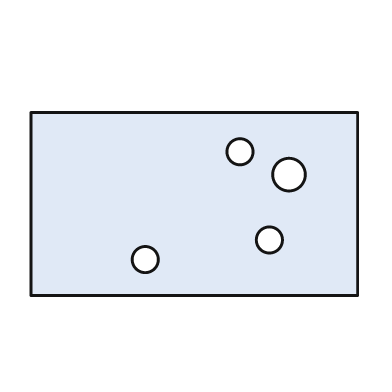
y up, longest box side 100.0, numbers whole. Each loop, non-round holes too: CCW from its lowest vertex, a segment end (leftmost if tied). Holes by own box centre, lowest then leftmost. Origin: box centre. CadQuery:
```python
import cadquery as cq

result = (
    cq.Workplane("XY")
    .moveTo(-50.0, -28.0)
    .lineTo(50.0, -28.0)
    .lineTo(50.0, 28.0)
    .lineTo(-50.0, 28.0)
    .close()
    .moveTo(-15.0, -17.0)
    .circle(4.0)
    .moveTo(23.0, -11.0)
    .circle(4.0)
    .moveTo(29.0, 9.0)
    .circle(5.0)
    .moveTo(14.0, 16.0)
    .circle(4.0)
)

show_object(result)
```